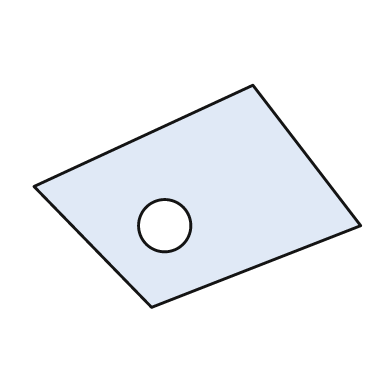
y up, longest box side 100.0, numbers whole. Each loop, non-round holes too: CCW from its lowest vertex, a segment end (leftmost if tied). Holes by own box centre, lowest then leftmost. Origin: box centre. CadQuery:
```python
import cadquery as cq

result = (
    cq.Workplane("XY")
    .moveTo(-14.0, -34.0)
    .lineTo(50.0, -9.0)
    .lineTo(17.0, 34.0)
    .lineTo(-50.0, 3.0)
    .close()
    .moveTo(-10.0, -9.0)
    .circle(8.0)
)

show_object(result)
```